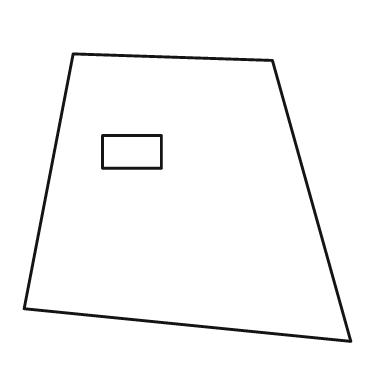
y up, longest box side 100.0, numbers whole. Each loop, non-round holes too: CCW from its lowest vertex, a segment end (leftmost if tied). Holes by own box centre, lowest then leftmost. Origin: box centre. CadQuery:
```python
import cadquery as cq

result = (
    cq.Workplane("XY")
    .moveTo(50.0, -44.0)
    .lineTo(26.0, 42.0)
    .lineTo(-35.0, 44.0)
    .lineTo(-50.0, -34.0)
    .close()
    .moveTo(-26.0, 9.0)
    .lineTo(-8.0, 9.0)
    .lineTo(-8.0, 19.0)
    .lineTo(-26.0, 19.0)
    .close()
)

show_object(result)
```